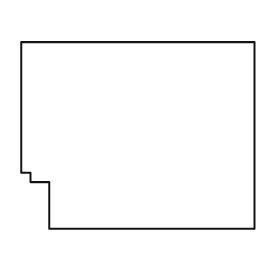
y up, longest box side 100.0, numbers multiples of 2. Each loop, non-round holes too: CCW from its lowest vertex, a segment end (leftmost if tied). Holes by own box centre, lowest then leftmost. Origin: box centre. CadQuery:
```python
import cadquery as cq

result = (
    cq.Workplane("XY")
    .moveTo(-38.0, -40.0)
    .lineTo(50.0, -40.0)
    .lineTo(50.0, 40.0)
    .lineTo(-50.0, 40.0)
    .lineTo(-50.0, -16.0)
    .lineTo(-46.0, -16.0)
    .lineTo(-46.0, -20.0)
    .lineTo(-38.0, -20.0)
    .close()
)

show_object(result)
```